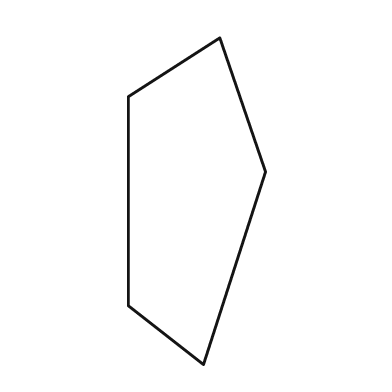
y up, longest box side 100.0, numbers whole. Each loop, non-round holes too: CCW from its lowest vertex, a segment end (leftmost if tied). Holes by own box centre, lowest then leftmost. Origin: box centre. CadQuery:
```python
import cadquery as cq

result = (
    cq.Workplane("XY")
    .moveTo(2.0, -50.0)
    .lineTo(21.0, 9.0)
    .lineTo(7.0, 50.0)
    .lineTo(-21.0, 32.0)
    .lineTo(-21.0, -32.0)
    .close()
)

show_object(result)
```